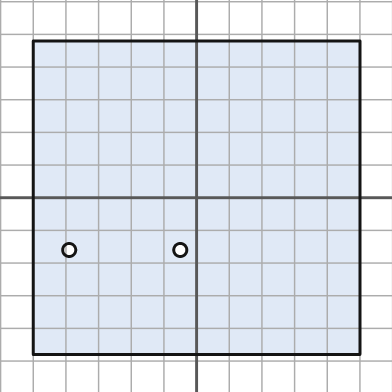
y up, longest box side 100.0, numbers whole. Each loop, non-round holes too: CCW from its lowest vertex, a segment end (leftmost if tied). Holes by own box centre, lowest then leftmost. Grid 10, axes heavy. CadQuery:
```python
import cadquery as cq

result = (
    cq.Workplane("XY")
    .moveTo(-50.0, -48.0)
    .lineTo(50.0, -48.0)
    .lineTo(50.0, 48.0)
    .lineTo(-50.0, 48.0)
    .close()
    .moveTo(-39.0, -16.0)
    .circle(2.0)
    .moveTo(-5.0, -16.0)
    .circle(2.0)
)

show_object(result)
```